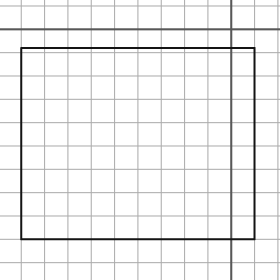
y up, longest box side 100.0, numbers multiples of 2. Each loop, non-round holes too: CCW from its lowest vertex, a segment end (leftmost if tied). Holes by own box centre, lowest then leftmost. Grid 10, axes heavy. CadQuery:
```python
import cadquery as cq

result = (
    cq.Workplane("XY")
    .moveTo(-90.0, -90.0)
    .lineTo(10.0, -90.0)
    .lineTo(10.0, -8.0)
    .lineTo(-90.0, -8.0)
    .close()
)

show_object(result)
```